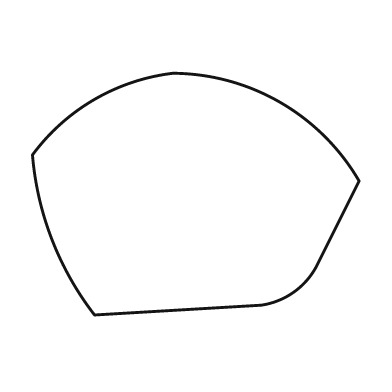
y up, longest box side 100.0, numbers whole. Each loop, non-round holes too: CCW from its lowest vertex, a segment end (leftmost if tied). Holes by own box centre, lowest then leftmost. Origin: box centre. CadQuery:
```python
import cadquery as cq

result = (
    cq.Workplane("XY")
    .moveTo(-31.0, -37.0)
    .lineTo(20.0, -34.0)
    .threePointArc((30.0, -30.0), (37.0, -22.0))
    .lineTo(50.0, 4.0)
    .threePointArc((26.0, 28.0), (-7.0, 37.0))
    .threePointArc((-31.0, 29.0), (-50.0, 12.0))
    .threePointArc((-44.0, -14.0), (-31.0, -37.0))
    .close()
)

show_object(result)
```